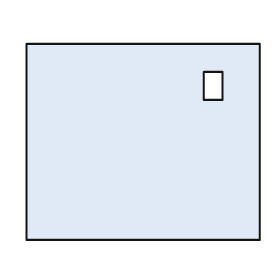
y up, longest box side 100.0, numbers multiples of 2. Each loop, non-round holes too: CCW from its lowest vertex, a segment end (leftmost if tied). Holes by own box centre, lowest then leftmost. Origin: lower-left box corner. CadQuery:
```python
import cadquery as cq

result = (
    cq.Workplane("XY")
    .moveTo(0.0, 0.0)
    .lineTo(100.0, 0.0)
    .lineTo(100.0, 84.0)
    .lineTo(0.0, 84.0)
    .close()
    .moveTo(76.0, 60.0)
    .lineTo(84.0, 60.0)
    .lineTo(84.0, 72.0)
    .lineTo(76.0, 72.0)
    .close()
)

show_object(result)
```